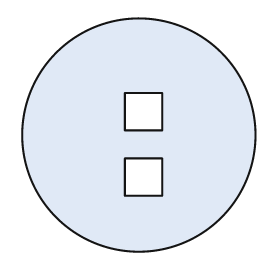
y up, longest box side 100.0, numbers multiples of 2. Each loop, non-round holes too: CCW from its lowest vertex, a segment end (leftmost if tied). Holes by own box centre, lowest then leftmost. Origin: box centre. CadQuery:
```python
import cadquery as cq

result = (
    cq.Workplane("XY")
    .moveTo(0.0, 0.0)
    .circle(50.0)
    .moveTo(-6.0, -26.0)
    .lineTo(10.0, -26.0)
    .lineTo(10.0, -10.0)
    .lineTo(-6.0, -10.0)
    .close()
    .moveTo(-6.0, 2.0)
    .lineTo(10.0, 2.0)
    .lineTo(10.0, 18.0)
    .lineTo(-6.0, 18.0)
    .close()
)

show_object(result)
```